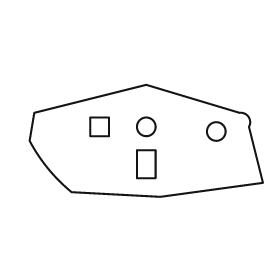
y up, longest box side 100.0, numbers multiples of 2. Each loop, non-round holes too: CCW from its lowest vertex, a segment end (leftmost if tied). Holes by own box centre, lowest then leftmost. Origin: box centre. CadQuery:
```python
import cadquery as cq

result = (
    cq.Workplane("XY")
    .moveTo(6.0, -24.0)
    .lineTo(50.0, -18.0)
    .lineTo(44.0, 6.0)
    .threePointArc((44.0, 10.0), (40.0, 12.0))
    .lineTo(0.0, 24.0)
    .lineTo(-48.0, 12.0)
    .lineTo(-50.0, 0.0)
    .threePointArc((-42.0, -12.0), (-32.0, -22.0))
    .close()
    .moveTo(-4.0, -16.0)
    .lineTo(4.0, -16.0)
    .lineTo(4.0, -4.0)
    .lineTo(-4.0, -4.0)
    .close()
    .moveTo(30.0, 4.0)
    .circle(4.0)
    .moveTo(-24.0, 2.0)
    .lineTo(-16.0, 2.0)
    .lineTo(-16.0, 10.0)
    .lineTo(-24.0, 10.0)
    .close()
    .moveTo(0.0, 6.0)
    .circle(4.0)
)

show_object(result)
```